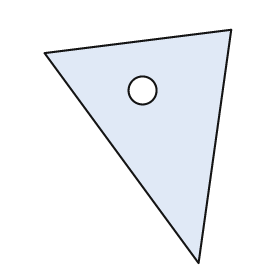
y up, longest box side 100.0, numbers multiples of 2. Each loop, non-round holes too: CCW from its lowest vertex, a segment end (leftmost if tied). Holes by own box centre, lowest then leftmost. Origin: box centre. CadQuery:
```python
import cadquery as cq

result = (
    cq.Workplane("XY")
    .moveTo(26.0, -50.0)
    .lineTo(40.0, 50.0)
    .lineTo(-40.0, 40.0)
    .close()
    .moveTo(2.0, 24.0)
    .circle(6.0)
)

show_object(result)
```